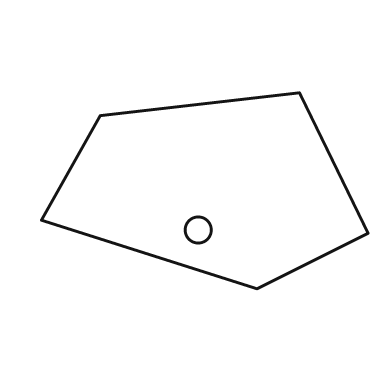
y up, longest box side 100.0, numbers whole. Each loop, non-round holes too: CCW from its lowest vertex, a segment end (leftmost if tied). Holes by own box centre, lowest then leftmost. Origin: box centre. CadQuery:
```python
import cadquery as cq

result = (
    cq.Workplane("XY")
    .moveTo(16.0, -30.0)
    .lineTo(50.0, -13.0)
    .lineTo(29.0, 30.0)
    .lineTo(-32.0, 23.0)
    .lineTo(-50.0, -9.0)
    .close()
    .moveTo(-2.0, -12.0)
    .circle(4.0)
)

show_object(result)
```